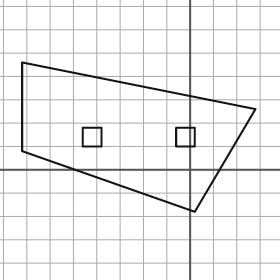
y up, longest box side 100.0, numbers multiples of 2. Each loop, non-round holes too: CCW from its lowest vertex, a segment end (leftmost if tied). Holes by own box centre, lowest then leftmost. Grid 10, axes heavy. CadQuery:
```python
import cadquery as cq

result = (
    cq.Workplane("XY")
    .moveTo(2.0, -18.0)
    .lineTo(28.0, 26.0)
    .lineTo(-72.0, 46.0)
    .lineTo(-72.0, 8.0)
    .close()
    .moveTo(-46.0, 10.0)
    .lineTo(-38.0, 10.0)
    .lineTo(-38.0, 18.0)
    .lineTo(-46.0, 18.0)
    .close()
    .moveTo(-6.0, 10.0)
    .lineTo(2.0, 10.0)
    .lineTo(2.0, 18.0)
    .lineTo(-6.0, 18.0)
    .close()
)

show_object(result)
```